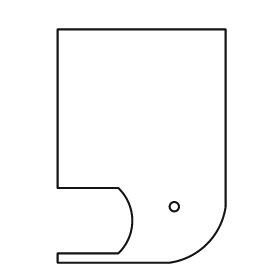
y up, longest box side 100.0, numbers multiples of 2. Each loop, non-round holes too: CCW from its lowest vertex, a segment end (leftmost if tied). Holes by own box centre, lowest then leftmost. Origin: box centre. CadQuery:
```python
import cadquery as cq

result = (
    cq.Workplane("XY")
    .moveTo(-36.0, -50.0)
    .lineTo(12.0, -50.0)
    .threePointArc((28.0, -42.0), (36.0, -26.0))
    .lineTo(36.0, 50.0)
    .lineTo(-36.0, 50.0)
    .lineTo(-36.0, -18.0)
    .lineTo(-10.0, -18.0)
    .threePointArc((-4.0, -32.0), (-10.0, -46.0))
    .lineTo(-36.0, -46.0)
    .close()
    .moveTo(14.0, -26.0)
    .circle(2.0)
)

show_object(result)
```